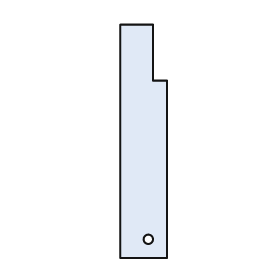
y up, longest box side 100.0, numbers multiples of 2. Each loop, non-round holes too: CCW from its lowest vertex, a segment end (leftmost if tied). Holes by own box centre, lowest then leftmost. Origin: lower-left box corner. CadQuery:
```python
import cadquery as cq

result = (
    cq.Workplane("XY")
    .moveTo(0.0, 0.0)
    .lineTo(20.0, 0.0)
    .lineTo(20.0, 76.0)
    .lineTo(14.0, 76.0)
    .lineTo(14.0, 100.0)
    .lineTo(0.0, 100.0)
    .close()
    .moveTo(12.0, 8.0)
    .circle(2.0)
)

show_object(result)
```